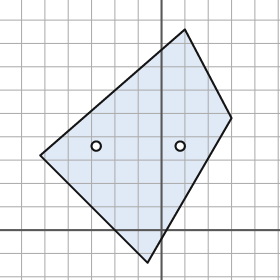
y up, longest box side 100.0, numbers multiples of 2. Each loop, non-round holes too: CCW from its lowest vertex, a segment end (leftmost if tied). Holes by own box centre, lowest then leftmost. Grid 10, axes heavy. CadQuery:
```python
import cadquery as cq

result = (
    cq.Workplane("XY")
    .moveTo(-6.0, -14.0)
    .lineTo(30.0, 48.0)
    .lineTo(10.0, 86.0)
    .lineTo(-52.0, 32.0)
    .close()
    .moveTo(-28.0, 36.0)
    .circle(2.0)
    .moveTo(8.0, 36.0)
    .circle(2.0)
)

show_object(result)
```